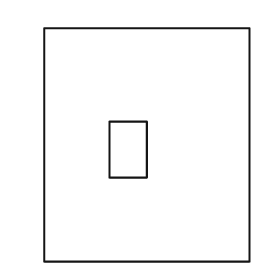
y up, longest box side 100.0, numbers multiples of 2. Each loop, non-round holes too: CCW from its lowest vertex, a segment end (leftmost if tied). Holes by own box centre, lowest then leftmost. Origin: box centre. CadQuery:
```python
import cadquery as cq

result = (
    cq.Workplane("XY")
    .moveTo(-44.0, -50.0)
    .lineTo(44.0, -50.0)
    .lineTo(44.0, 50.0)
    .lineTo(-44.0, 50.0)
    .close()
    .moveTo(-16.0, -14.0)
    .lineTo(0.0, -14.0)
    .lineTo(0.0, 10.0)
    .lineTo(-16.0, 10.0)
    .close()
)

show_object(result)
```